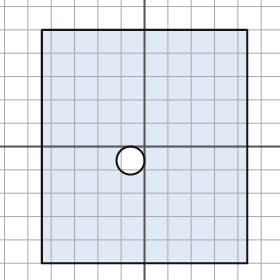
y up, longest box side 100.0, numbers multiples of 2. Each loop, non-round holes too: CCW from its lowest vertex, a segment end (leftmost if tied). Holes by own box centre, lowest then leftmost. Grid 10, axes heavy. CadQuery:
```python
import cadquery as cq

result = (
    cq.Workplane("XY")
    .moveTo(-44.0, -50.0)
    .lineTo(44.0, -50.0)
    .lineTo(44.0, 50.0)
    .lineTo(-44.0, 50.0)
    .close()
    .moveTo(-6.0, -6.0)
    .circle(6.0)
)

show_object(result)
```